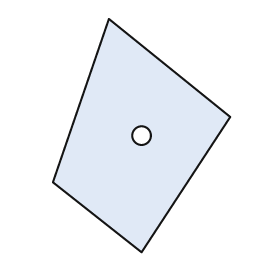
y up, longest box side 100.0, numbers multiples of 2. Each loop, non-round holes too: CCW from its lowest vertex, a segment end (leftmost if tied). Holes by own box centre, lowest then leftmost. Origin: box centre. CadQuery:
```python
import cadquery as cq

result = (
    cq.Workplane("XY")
    .moveTo(0.0, -50.0)
    .lineTo(38.0, 8.0)
    .lineTo(-14.0, 50.0)
    .lineTo(-38.0, -20.0)
    .close()
    .moveTo(0.0, 0.0)
    .circle(4.0)
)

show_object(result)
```